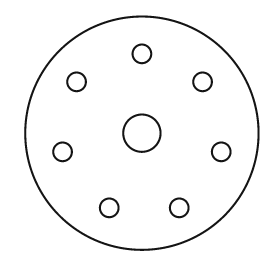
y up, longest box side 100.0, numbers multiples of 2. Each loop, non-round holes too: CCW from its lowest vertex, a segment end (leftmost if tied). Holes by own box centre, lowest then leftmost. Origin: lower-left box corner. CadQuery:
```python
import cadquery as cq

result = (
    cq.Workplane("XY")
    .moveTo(50.0, 50.0)
    .circle(50.0)
    .moveTo(36.0, 18.0)
    .circle(4.0)
    .moveTo(66.0, 18.0)
    .circle(4.0)
    .moveTo(16.0, 42.0)
    .circle(4.0)
    .moveTo(84.0, 42.0)
    .circle(4.0)
    .moveTo(50.0, 50.0)
    .circle(8.0)
    .moveTo(22.0, 72.0)
    .circle(4.0)
    .moveTo(76.0, 72.0)
    .circle(4.0)
    .moveTo(50.0, 84.0)
    .circle(4.0)
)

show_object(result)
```